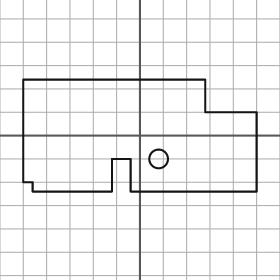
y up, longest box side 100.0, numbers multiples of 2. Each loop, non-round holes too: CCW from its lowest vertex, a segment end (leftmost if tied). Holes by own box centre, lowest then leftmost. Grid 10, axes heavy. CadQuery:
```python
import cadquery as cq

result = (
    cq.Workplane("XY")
    .moveTo(-46.0, -24.0)
    .lineTo(-12.0, -24.0)
    .lineTo(-12.0, -10.0)
    .lineTo(-4.0, -10.0)
    .lineTo(-4.0, -24.0)
    .lineTo(50.0, -24.0)
    .lineTo(50.0, 10.0)
    .lineTo(28.0, 10.0)
    .lineTo(28.0, 24.0)
    .lineTo(-50.0, 24.0)
    .lineTo(-50.0, -20.0)
    .lineTo(-46.0, -20.0)
    .close()
    .moveTo(8.0, -10.0)
    .circle(4.0)
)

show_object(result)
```